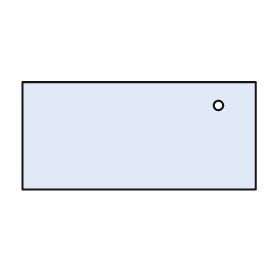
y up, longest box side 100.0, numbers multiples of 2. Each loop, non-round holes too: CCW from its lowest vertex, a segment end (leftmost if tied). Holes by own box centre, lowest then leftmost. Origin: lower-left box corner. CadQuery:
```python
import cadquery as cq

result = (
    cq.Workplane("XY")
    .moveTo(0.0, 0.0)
    .lineTo(100.0, 0.0)
    .lineTo(100.0, 46.0)
    .lineTo(0.0, 46.0)
    .close()
    .moveTo(84.0, 36.0)
    .circle(2.0)
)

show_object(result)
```